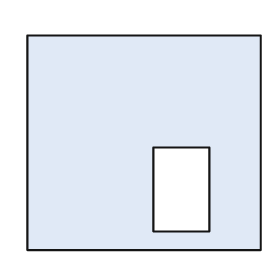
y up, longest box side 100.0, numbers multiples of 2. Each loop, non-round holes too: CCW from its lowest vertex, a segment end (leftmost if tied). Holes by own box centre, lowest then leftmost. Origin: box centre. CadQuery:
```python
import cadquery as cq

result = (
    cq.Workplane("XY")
    .moveTo(-50.0, -46.0)
    .lineTo(50.0, -46.0)
    .lineTo(50.0, 46.0)
    .lineTo(-50.0, 46.0)
    .close()
    .moveTo(4.0, -38.0)
    .lineTo(28.0, -38.0)
    .lineTo(28.0, -2.0)
    .lineTo(4.0, -2.0)
    .close()
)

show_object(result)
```